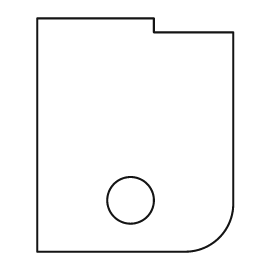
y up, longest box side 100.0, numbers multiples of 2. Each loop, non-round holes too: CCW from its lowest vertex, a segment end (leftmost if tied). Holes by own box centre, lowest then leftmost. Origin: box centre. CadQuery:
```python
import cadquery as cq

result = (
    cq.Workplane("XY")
    .moveTo(-42.0, -50.0)
    .lineTo(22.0, -50.0)
    .threePointArc((36.0, -44.0), (42.0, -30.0))
    .lineTo(42.0, 44.0)
    .lineTo(8.0, 44.0)
    .lineTo(8.0, 50.0)
    .lineTo(-42.0, 50.0)
    .close()
    .moveTo(-2.0, -28.0)
    .circle(10.0)
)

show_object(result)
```